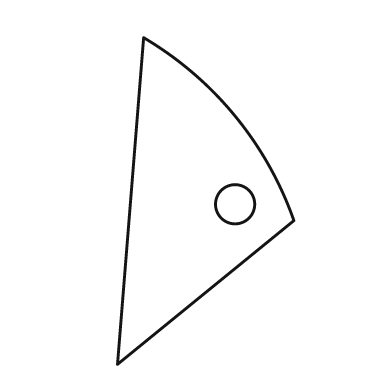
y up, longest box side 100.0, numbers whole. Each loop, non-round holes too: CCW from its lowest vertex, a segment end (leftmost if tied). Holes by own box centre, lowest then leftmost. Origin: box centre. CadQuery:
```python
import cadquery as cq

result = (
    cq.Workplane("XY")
    .moveTo(-27.0, -50.0)
    .lineTo(27.0, -6.0)
    .threePointArc((9.0, 26.0), (-19.0, 50.0))
    .close()
    .moveTo(9.0, -1.0)
    .circle(6.0)
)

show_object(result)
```